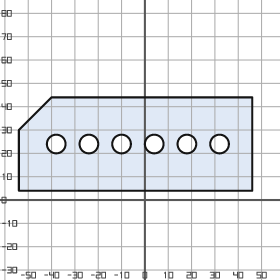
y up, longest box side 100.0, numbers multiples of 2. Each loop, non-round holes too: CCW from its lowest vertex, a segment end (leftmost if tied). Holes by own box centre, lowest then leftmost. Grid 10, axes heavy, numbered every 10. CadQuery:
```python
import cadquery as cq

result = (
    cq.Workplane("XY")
    .moveTo(-54.0, 4.0)
    .lineTo(46.0, 4.0)
    .lineTo(46.0, 44.0)
    .lineTo(-40.0, 44.0)
    .lineTo(-54.0, 30.0)
    .close()
    .moveTo(-38.0, 24.0)
    .circle(4.0)
    .moveTo(-24.0, 24.0)
    .circle(4.0)
    .moveTo(-10.0, 24.0)
    .circle(4.0)
    .moveTo(4.0, 24.0)
    .circle(4.0)
    .moveTo(18.0, 24.0)
    .circle(4.0)
    .moveTo(32.0, 24.0)
    .circle(4.0)
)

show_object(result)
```